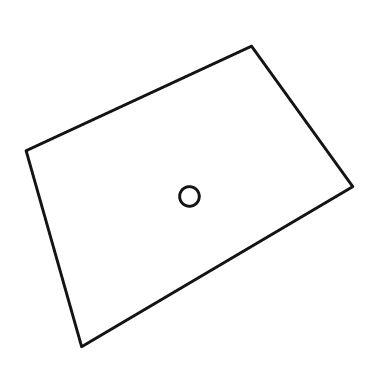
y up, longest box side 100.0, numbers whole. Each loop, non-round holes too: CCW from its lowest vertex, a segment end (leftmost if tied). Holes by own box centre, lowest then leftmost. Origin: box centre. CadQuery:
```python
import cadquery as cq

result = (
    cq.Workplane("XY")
    .moveTo(-33.0, -46.0)
    .lineTo(50.0, 3.0)
    .lineTo(19.0, 46.0)
    .lineTo(-50.0, 14.0)
    .close()
    .moveTo(0.0, 0.0)
    .circle(3.0)
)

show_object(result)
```